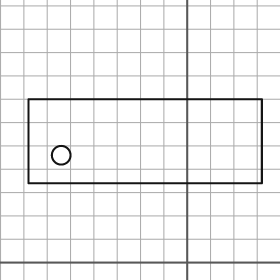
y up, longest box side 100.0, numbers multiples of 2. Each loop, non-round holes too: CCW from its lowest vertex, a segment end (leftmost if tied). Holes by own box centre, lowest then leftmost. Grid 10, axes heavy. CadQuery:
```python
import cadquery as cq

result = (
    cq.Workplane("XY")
    .moveTo(-68.0, 34.0)
    .lineTo(32.0, 34.0)
    .lineTo(32.0, 70.0)
    .lineTo(-68.0, 70.0)
    .close()
    .moveTo(-54.0, 46.0)
    .circle(4.0)
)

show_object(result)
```